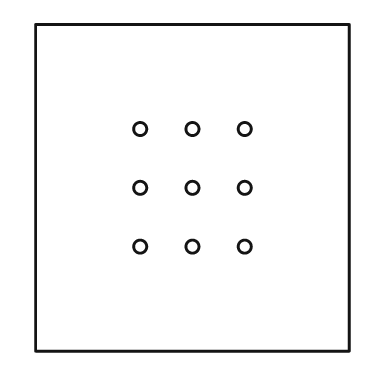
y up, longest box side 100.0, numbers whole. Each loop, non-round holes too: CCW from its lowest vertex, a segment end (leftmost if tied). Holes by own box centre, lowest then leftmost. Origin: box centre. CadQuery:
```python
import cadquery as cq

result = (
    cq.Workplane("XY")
    .moveTo(-48.0, -50.0)
    .lineTo(48.0, -50.0)
    .lineTo(48.0, 50.0)
    .lineTo(-48.0, 50.0)
    .close()
    .moveTo(-16.0, -18.0)
    .circle(2.0)
    .moveTo(0.0, -18.0)
    .circle(2.0)
    .moveTo(16.0, -18.0)
    .circle(2.0)
    .moveTo(-16.0, 0.0)
    .circle(2.0)
    .moveTo(0.0, 0.0)
    .circle(2.0)
    .moveTo(16.0, 0.0)
    .circle(2.0)
    .moveTo(-16.0, 18.0)
    .circle(2.0)
    .moveTo(0.0, 18.0)
    .circle(2.0)
    .moveTo(16.0, 18.0)
    .circle(2.0)
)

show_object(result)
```